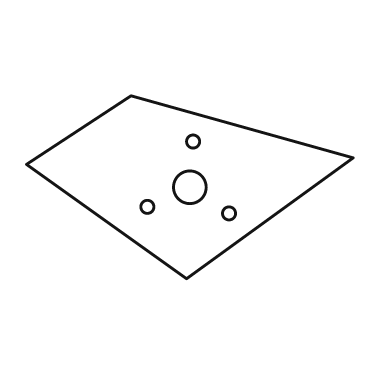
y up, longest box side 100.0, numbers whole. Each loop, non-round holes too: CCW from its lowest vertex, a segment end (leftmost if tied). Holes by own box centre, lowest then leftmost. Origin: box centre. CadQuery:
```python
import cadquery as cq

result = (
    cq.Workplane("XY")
    .moveTo(-1.0, -28.0)
    .lineTo(50.0, 9.0)
    .lineTo(-18.0, 28.0)
    .lineTo(-50.0, 7.0)
    .close()
    .moveTo(12.0, -8.0)
    .circle(2.0)
    .moveTo(-13.0, -6.0)
    .circle(2.0)
    .moveTo(0.0, 0.0)
    .circle(5.0)
    .moveTo(1.0, 14.0)
    .circle(2.0)
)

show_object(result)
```